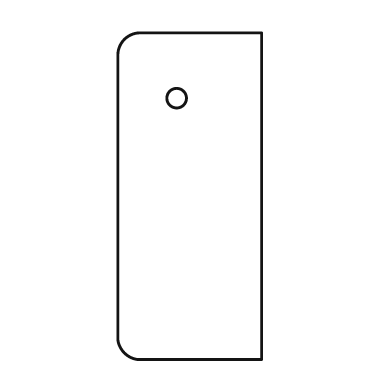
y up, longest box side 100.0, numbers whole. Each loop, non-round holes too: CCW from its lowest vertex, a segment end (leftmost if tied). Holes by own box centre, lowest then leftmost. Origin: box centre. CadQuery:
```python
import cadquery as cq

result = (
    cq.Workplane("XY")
    .moveTo(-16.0, -50.0)
    .lineTo(22.0, -50.0)
    .lineTo(22.0, 50.0)
    .lineTo(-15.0, 50.0)
    .threePointArc((-20.0, 48.0), (-22.0, 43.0))
    .lineTo(-22.0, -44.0)
    .threePointArc((-20.0, -48.0), (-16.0, -50.0))
    .close()
    .moveTo(-4.0, 30.0)
    .circle(3.0)
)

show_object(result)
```